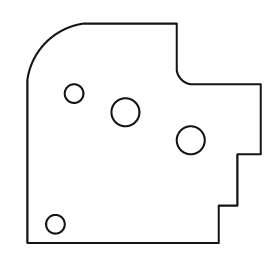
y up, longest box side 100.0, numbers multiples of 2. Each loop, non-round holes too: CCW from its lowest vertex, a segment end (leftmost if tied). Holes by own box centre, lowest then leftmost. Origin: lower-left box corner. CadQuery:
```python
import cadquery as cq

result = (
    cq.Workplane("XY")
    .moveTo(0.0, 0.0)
    .lineTo(82.0, 0.0)
    .lineTo(82.0, 16.0)
    .lineTo(90.0, 16.0)
    .lineTo(90.0, 38.0)
    .lineTo(100.0, 38.0)
    .lineTo(100.0, 68.0)
    .lineTo(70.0, 68.0)
    .threePointArc((66.0, 70.0), (64.0, 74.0))
    .lineTo(64.0, 94.0)
    .lineTo(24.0, 94.0)
    .threePointArc((8.0, 86.0), (0.0, 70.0))
    .close()
    .moveTo(12.0, 8.0)
    .circle(4.0)
    .moveTo(70.0, 44.0)
    .circle(6.0)
    .moveTo(42.0, 56.0)
    .circle(6.0)
    .moveTo(20.0, 64.0)
    .circle(4.0)
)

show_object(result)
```